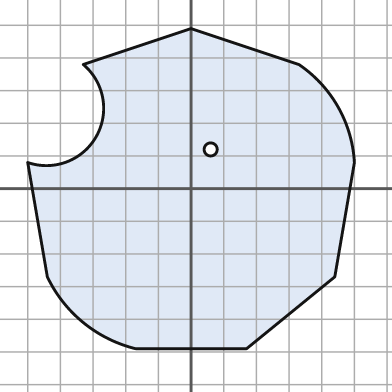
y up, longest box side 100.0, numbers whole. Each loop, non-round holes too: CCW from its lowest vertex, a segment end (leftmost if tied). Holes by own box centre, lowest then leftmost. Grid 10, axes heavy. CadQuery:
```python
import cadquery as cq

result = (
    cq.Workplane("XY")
    .moveTo(-17.0, -49.0)
    .lineTo(17.0, -49.0)
    .lineTo(44.0, -27.0)
    .lineTo(50.0, 8.0)
    .threePointArc((45.0, 25.0), (33.0, 38.0))
    .lineTo(0.0, 49.0)
    .lineTo(-33.0, 38.0)
    .threePointArc((-29.0, 16.0), (-50.0, 8.0))
    .lineTo(-44.0, -27.0)
    .threePointArc((-33.0, -41.0), (-17.0, -49.0))
    .close()
    .moveTo(6.0, 12.0)
    .circle(2.0)
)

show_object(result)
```